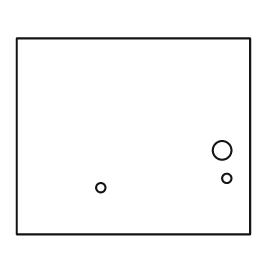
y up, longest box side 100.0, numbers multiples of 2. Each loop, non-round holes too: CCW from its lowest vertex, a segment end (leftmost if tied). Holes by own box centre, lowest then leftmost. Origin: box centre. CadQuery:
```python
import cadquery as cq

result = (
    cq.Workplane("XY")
    .moveTo(-50.0, -42.0)
    .lineTo(50.0, -42.0)
    .lineTo(50.0, 42.0)
    .lineTo(-50.0, 42.0)
    .close()
    .moveTo(-14.0, -22.0)
    .circle(2.0)
    .moveTo(40.0, -18.0)
    .circle(2.0)
    .moveTo(38.0, -6.0)
    .circle(4.0)
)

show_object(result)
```